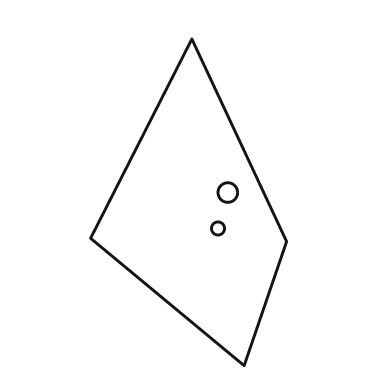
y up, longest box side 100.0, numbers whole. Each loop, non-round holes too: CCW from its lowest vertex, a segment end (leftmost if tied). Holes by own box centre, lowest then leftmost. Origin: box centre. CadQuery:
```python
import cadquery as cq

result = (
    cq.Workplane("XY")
    .moveTo(17.0, -50.0)
    .lineTo(30.0, -12.0)
    .lineTo(1.0, 50.0)
    .lineTo(-30.0, -11.0)
    .close()
    .moveTo(9.0, -8.0)
    .circle(2.0)
    .moveTo(12.0, 3.0)
    .circle(3.0)
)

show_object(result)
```